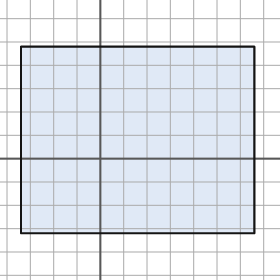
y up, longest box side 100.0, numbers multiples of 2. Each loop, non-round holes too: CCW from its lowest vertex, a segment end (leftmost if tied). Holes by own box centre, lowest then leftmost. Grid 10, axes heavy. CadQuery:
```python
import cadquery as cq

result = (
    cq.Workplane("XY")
    .moveTo(-34.0, -32.0)
    .lineTo(66.0, -32.0)
    .lineTo(66.0, 48.0)
    .lineTo(-34.0, 48.0)
    .close()
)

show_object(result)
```